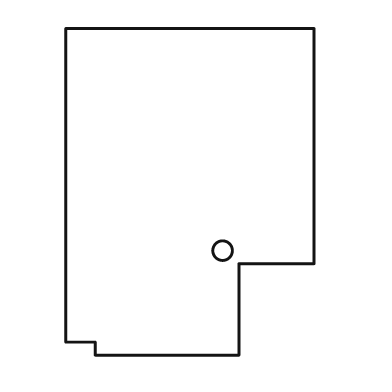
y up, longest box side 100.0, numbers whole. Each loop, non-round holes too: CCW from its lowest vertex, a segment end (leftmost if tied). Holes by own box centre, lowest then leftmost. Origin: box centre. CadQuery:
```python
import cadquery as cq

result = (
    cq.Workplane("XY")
    .moveTo(-29.0, -50.0)
    .lineTo(15.0, -50.0)
    .lineTo(15.0, -22.0)
    .lineTo(38.0, -22.0)
    .lineTo(38.0, 50.0)
    .lineTo(-38.0, 50.0)
    .lineTo(-38.0, -46.0)
    .lineTo(-29.0, -46.0)
    .close()
    .moveTo(10.0, -18.0)
    .circle(3.0)
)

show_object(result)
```